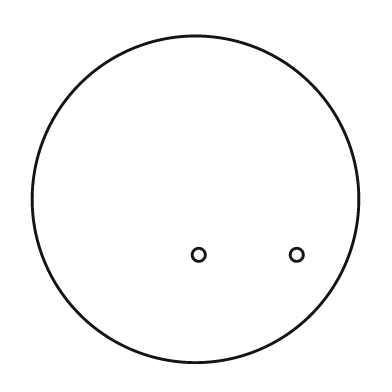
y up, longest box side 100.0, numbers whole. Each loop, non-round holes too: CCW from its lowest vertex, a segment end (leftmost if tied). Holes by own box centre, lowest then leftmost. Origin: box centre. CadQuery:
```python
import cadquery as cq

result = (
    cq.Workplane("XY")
    .moveTo(0.0, 0.0)
    .circle(50.0)
    .moveTo(1.0, -17.0)
    .circle(2.0)
    .moveTo(31.0, -17.0)
    .circle(2.0)
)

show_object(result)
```